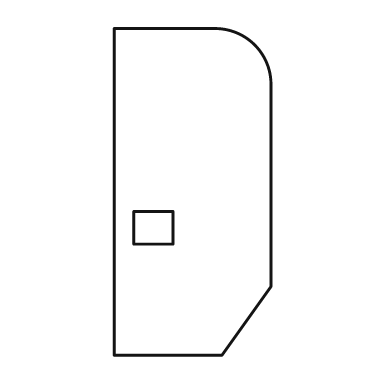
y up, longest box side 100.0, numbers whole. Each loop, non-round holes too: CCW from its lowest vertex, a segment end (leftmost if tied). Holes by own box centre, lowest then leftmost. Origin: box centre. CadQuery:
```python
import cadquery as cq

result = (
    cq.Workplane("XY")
    .moveTo(-24.0, -50.0)
    .lineTo(9.0, -50.0)
    .lineTo(24.0, -29.0)
    .lineTo(24.0, 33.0)
    .threePointArc((19.0, 45.0), (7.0, 50.0))
    .lineTo(-24.0, 50.0)
    .close()
    .moveTo(-18.0, -16.0)
    .lineTo(-6.0, -16.0)
    .lineTo(-6.0, -6.0)
    .lineTo(-18.0, -6.0)
    .close()
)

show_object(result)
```